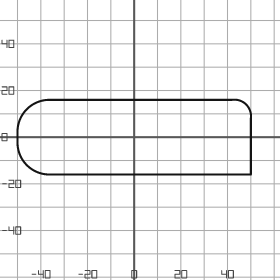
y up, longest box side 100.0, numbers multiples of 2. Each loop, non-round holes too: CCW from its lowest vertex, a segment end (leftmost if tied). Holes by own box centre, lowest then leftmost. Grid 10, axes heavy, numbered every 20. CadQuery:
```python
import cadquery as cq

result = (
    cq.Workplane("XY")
    .moveTo(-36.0, -16.0)
    .lineTo(50.0, -16.0)
    .lineTo(50.0, 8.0)
    .threePointArc((48.0, 14.0), (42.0, 16.0))
    .lineTo(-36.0, 16.0)
    .threePointArc((-46.0, 12.0), (-50.0, 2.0))
    .lineTo(-50.0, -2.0)
    .threePointArc((-46.0, -12.0), (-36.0, -16.0))
    .close()
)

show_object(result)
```